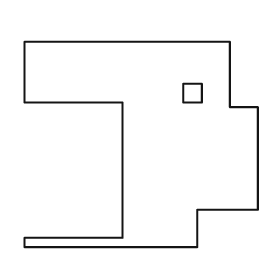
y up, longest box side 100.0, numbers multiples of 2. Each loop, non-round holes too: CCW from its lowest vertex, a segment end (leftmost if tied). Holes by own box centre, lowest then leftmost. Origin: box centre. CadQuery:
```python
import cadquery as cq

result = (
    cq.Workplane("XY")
    .moveTo(-50.0, -44.0)
    .lineTo(24.0, -44.0)
    .lineTo(24.0, -28.0)
    .lineTo(50.0, -28.0)
    .lineTo(50.0, 16.0)
    .lineTo(38.0, 16.0)
    .lineTo(38.0, 44.0)
    .lineTo(-50.0, 44.0)
    .lineTo(-50.0, 18.0)
    .lineTo(-8.0, 18.0)
    .lineTo(-8.0, -40.0)
    .lineTo(-50.0, -40.0)
    .close()
    .moveTo(18.0, 18.0)
    .lineTo(26.0, 18.0)
    .lineTo(26.0, 26.0)
    .lineTo(18.0, 26.0)
    .close()
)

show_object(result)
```